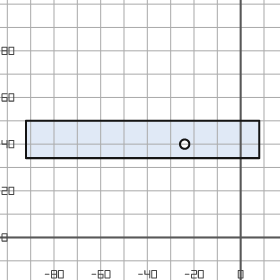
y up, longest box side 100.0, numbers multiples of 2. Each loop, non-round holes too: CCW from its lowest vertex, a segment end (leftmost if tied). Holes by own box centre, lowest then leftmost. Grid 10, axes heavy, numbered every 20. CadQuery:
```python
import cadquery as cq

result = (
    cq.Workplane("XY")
    .moveTo(-92.0, 34.0)
    .lineTo(8.0, 34.0)
    .lineTo(8.0, 50.0)
    .lineTo(-92.0, 50.0)
    .close()
    .moveTo(-24.0, 40.0)
    .circle(2.0)
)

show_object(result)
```